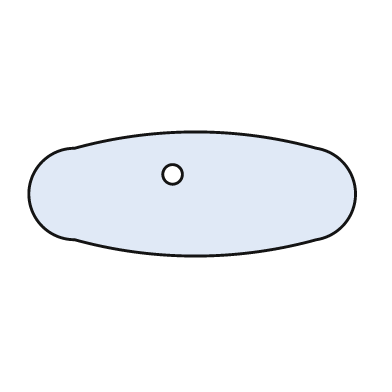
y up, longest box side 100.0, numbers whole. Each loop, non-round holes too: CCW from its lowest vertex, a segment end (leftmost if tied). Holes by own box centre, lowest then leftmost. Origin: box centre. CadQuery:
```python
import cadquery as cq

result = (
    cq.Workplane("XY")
    .moveTo(-36.0, -14.0)
    .threePointArc((1.0, -19.0), (38.0, -14.0))
    .threePointArc((50.0, 0.0), (38.0, 14.0))
    .threePointArc((1.0, 19.0), (-36.0, 14.0))
    .threePointArc((-50.0, 0.0), (-36.0, -14.0))
    .close()
    .moveTo(-6.0, 6.0)
    .circle(3.0)
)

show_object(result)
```